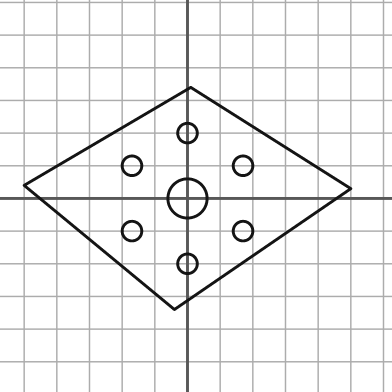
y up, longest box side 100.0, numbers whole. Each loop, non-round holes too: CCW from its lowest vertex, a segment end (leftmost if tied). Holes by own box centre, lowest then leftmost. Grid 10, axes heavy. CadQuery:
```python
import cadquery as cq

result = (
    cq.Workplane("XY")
    .moveTo(-4.0, -34.0)
    .lineTo(50.0, 3.0)
    .lineTo(1.0, 34.0)
    .lineTo(-50.0, 4.0)
    .close()
    .moveTo(0.0, -20.0)
    .circle(3.0)
    .moveTo(-17.0, -10.0)
    .circle(3.0)
    .moveTo(17.0, -10.0)
    .circle(3.0)
    .moveTo(0.0, 0.0)
    .circle(6.0)
    .moveTo(-17.0, 10.0)
    .circle(3.0)
    .moveTo(17.0, 10.0)
    .circle(3.0)
    .moveTo(0.0, 20.0)
    .circle(3.0)
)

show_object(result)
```